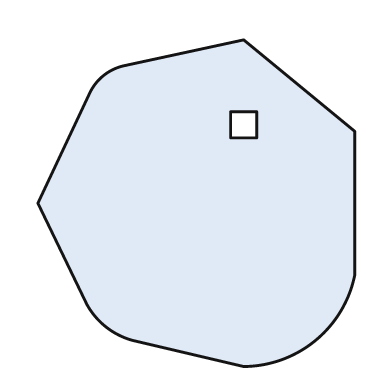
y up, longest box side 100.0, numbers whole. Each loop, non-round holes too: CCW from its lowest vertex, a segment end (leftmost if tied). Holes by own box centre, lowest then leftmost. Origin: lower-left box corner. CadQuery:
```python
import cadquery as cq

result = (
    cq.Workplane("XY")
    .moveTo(63.0, 0.0)
    .threePointArc((85.0, 8.0), (97.0, 28.0))
    .lineTo(97.0, 72.0)
    .lineTo(63.0, 100.0)
    .lineTo(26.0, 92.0)
    .threePointArc((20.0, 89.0), (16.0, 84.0))
    .lineTo(0.0, 50.0)
    .lineTo(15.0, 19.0)
    .threePointArc((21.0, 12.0), (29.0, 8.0))
    .close()
    .moveTo(59.0, 70.0)
    .lineTo(67.0, 70.0)
    .lineTo(67.0, 78.0)
    .lineTo(59.0, 78.0)
    .close()
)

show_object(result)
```